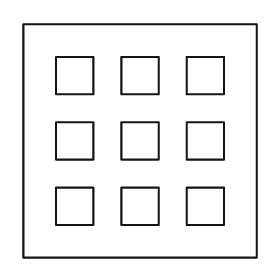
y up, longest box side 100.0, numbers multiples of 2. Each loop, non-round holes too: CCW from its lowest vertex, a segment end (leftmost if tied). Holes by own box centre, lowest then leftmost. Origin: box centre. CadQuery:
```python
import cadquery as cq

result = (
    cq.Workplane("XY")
    .moveTo(-50.0, -50.0)
    .lineTo(50.0, -50.0)
    .lineTo(50.0, 50.0)
    .lineTo(-50.0, 50.0)
    .close()
    .moveTo(-36.0, -36.0)
    .lineTo(-20.0, -36.0)
    .lineTo(-20.0, -20.0)
    .lineTo(-36.0, -20.0)
    .close()
    .moveTo(-8.0, -36.0)
    .lineTo(8.0, -36.0)
    .lineTo(8.0, -20.0)
    .lineTo(-8.0, -20.0)
    .close()
    .moveTo(20.0, -36.0)
    .lineTo(36.0, -36.0)
    .lineTo(36.0, -20.0)
    .lineTo(20.0, -20.0)
    .close()
    .moveTo(-36.0, -8.0)
    .lineTo(-20.0, -8.0)
    .lineTo(-20.0, 8.0)
    .lineTo(-36.0, 8.0)
    .close()
    .moveTo(-8.0, -8.0)
    .lineTo(8.0, -8.0)
    .lineTo(8.0, 8.0)
    .lineTo(-8.0, 8.0)
    .close()
    .moveTo(20.0, -8.0)
    .lineTo(36.0, -8.0)
    .lineTo(36.0, 8.0)
    .lineTo(20.0, 8.0)
    .close()
    .moveTo(-36.0, 20.0)
    .lineTo(-20.0, 20.0)
    .lineTo(-20.0, 36.0)
    .lineTo(-36.0, 36.0)
    .close()
    .moveTo(-8.0, 20.0)
    .lineTo(8.0, 20.0)
    .lineTo(8.0, 36.0)
    .lineTo(-8.0, 36.0)
    .close()
    .moveTo(20.0, 20.0)
    .lineTo(36.0, 20.0)
    .lineTo(36.0, 36.0)
    .lineTo(20.0, 36.0)
    .close()
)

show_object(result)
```